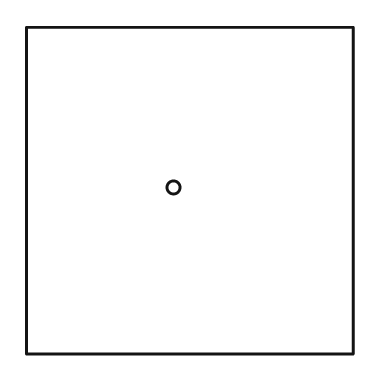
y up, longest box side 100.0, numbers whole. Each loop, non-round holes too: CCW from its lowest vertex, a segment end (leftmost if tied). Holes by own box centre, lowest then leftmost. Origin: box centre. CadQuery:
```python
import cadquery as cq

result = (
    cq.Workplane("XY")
    .moveTo(-50.0, -50.0)
    .lineTo(50.0, -50.0)
    .lineTo(50.0, 50.0)
    .lineTo(-50.0, 50.0)
    .close()
    .moveTo(-5.0, 1.0)
    .circle(2.0)
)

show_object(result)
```